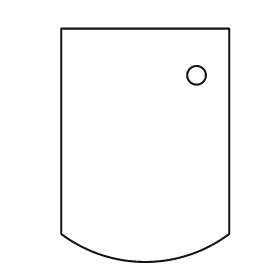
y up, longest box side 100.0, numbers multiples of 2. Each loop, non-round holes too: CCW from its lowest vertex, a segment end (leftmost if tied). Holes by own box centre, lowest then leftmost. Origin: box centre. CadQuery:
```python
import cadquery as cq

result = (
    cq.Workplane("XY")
    .moveTo(-36.0, -38.0)
    .threePointArc((0.0, -50.0), (36.0, -38.0))
    .lineTo(36.0, 50.0)
    .lineTo(-36.0, 50.0)
    .close()
    .moveTo(22.0, 30.0)
    .circle(4.0)
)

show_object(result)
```